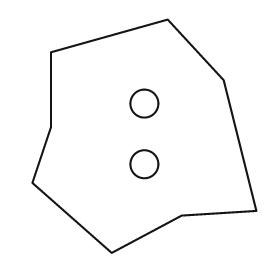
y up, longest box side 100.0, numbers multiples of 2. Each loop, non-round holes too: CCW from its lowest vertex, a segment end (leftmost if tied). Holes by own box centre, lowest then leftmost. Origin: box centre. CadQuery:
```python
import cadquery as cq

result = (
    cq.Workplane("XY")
    .moveTo(-14.0, -50.0)
    .lineTo(16.0, -34.0)
    .lineTo(48.0, -32.0)
    .lineTo(34.0, 24.0)
    .lineTo(10.0, 50.0)
    .lineTo(-40.0, 36.0)
    .lineTo(-40.0, 4.0)
    .lineTo(-48.0, -20.0)
    .close()
    .moveTo(0.0, -12.0)
    .circle(6.0)
    .moveTo(0.0, 14.0)
    .circle(6.0)
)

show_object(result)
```